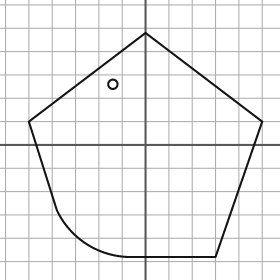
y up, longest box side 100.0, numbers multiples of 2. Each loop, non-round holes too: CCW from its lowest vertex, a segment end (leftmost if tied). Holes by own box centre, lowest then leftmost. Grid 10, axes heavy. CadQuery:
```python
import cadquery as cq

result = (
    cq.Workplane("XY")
    .moveTo(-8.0, -48.0)
    .lineTo(30.0, -48.0)
    .lineTo(50.0, 10.0)
    .lineTo(0.0, 48.0)
    .lineTo(-50.0, 10.0)
    .lineTo(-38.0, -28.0)
    .threePointArc((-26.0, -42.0), (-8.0, -48.0))
    .close()
    .moveTo(-14.0, 26.0)
    .circle(2.0)
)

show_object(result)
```